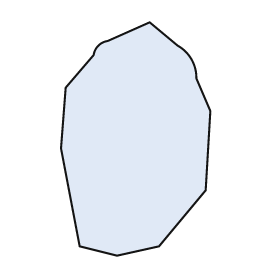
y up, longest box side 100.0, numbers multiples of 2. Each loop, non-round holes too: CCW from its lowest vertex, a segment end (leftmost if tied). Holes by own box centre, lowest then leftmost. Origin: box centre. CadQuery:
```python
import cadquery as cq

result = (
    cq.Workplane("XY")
    .moveTo(-8.0, -50.0)
    .lineTo(10.0, -46.0)
    .lineTo(30.0, -22.0)
    .lineTo(32.0, 12.0)
    .lineTo(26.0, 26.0)
    .threePointArc((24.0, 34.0), (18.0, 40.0))
    .lineTo(6.0, 50.0)
    .lineTo(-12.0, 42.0)
    .threePointArc((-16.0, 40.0), (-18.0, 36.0))
    .lineTo(-30.0, 22.0)
    .lineTo(-32.0, -4.0)
    .lineTo(-24.0, -46.0)
    .close()
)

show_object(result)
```